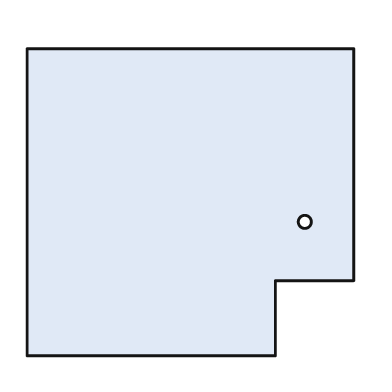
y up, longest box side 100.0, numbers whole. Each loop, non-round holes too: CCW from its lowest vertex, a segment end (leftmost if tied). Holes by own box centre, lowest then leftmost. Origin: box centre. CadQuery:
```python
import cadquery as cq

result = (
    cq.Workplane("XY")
    .moveTo(-50.0, -47.0)
    .lineTo(26.0, -47.0)
    .lineTo(26.0, -24.0)
    .lineTo(50.0, -24.0)
    .lineTo(50.0, 47.0)
    .lineTo(-50.0, 47.0)
    .close()
    .moveTo(35.0, -6.0)
    .circle(2.0)
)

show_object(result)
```